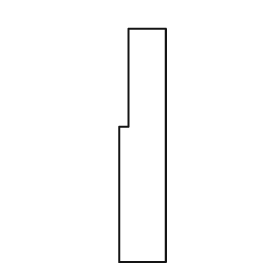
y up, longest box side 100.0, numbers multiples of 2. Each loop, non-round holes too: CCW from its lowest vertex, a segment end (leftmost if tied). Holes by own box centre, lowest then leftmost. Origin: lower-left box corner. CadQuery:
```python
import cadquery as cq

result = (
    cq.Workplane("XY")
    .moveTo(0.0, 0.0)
    .lineTo(20.0, 0.0)
    .lineTo(20.0, 100.0)
    .lineTo(4.0, 100.0)
    .lineTo(4.0, 58.0)
    .lineTo(0.0, 58.0)
    .close()
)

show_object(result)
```